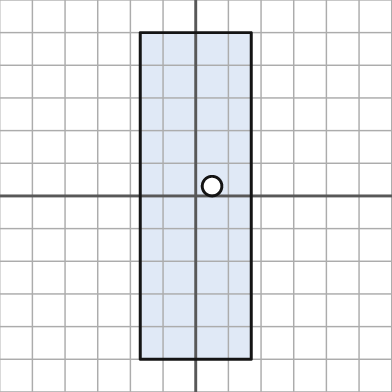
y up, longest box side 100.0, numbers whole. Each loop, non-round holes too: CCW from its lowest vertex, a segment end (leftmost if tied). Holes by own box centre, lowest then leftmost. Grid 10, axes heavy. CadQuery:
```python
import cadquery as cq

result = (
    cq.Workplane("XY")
    .moveTo(-17.0, -50.0)
    .lineTo(17.0, -50.0)
    .lineTo(17.0, 50.0)
    .lineTo(-17.0, 50.0)
    .close()
    .moveTo(5.0, 3.0)
    .circle(3.0)
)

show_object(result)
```